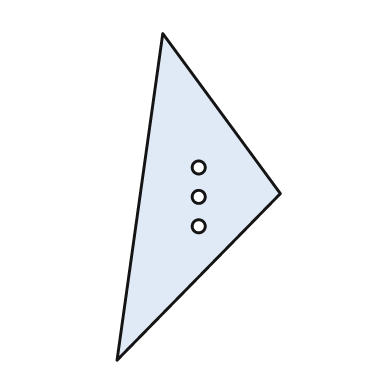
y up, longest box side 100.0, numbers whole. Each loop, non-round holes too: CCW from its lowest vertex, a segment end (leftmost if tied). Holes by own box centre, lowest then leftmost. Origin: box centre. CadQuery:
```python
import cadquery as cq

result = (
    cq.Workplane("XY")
    .moveTo(-25.0, -50.0)
    .lineTo(25.0, 1.0)
    .lineTo(-11.0, 50.0)
    .close()
    .moveTo(0.0, -9.0)
    .circle(2.0)
    .moveTo(0.0, 0.0)
    .circle(2.0)
    .moveTo(0.0, 9.0)
    .circle(2.0)
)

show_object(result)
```